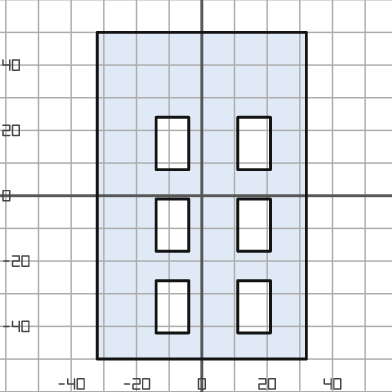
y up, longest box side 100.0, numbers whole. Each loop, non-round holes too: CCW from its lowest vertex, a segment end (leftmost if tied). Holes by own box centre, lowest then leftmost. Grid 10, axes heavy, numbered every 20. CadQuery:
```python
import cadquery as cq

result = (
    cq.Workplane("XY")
    .moveTo(-32.0, -50.0)
    .lineTo(32.0, -50.0)
    .lineTo(32.0, 50.0)
    .lineTo(-32.0, 50.0)
    .close()
    .moveTo(-14.0, -42.0)
    .lineTo(-4.0, -42.0)
    .lineTo(-4.0, -26.0)
    .lineTo(-14.0, -26.0)
    .close()
    .moveTo(11.0, -42.0)
    .lineTo(21.0, -42.0)
    .lineTo(21.0, -26.0)
    .lineTo(11.0, -26.0)
    .close()
    .moveTo(-14.0, -17.0)
    .lineTo(-4.0, -17.0)
    .lineTo(-4.0, -1.0)
    .lineTo(-14.0, -1.0)
    .close()
    .moveTo(11.0, -17.0)
    .lineTo(21.0, -17.0)
    .lineTo(21.0, -1.0)
    .lineTo(11.0, -1.0)
    .close()
    .moveTo(-14.0, 8.0)
    .lineTo(-4.0, 8.0)
    .lineTo(-4.0, 24.0)
    .lineTo(-14.0, 24.0)
    .close()
    .moveTo(11.0, 8.0)
    .lineTo(21.0, 8.0)
    .lineTo(21.0, 24.0)
    .lineTo(11.0, 24.0)
    .close()
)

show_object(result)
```